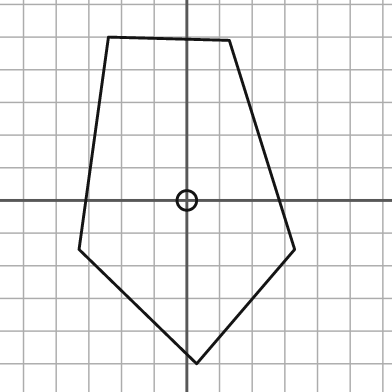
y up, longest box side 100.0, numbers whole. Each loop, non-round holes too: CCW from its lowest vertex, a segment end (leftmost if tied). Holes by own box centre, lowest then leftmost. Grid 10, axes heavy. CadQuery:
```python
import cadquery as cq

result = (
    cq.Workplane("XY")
    .moveTo(3.0, -50.0)
    .lineTo(33.0, -15.0)
    .lineTo(13.0, 49.0)
    .lineTo(-24.0, 50.0)
    .lineTo(-33.0, -15.0)
    .close()
    .moveTo(0.0, 0.0)
    .circle(3.0)
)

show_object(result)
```